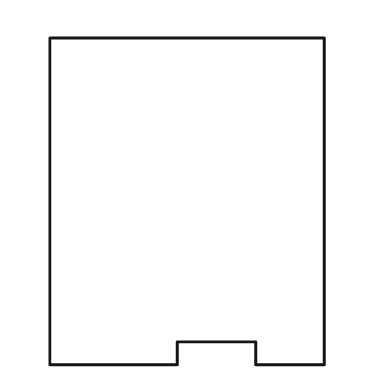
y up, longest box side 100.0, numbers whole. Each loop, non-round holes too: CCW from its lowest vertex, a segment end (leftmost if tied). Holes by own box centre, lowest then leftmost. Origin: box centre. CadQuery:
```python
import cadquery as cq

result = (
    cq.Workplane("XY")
    .moveTo(-42.0, -50.0)
    .lineTo(-3.0, -50.0)
    .lineTo(-3.0, -43.0)
    .lineTo(21.0, -43.0)
    .lineTo(21.0, -50.0)
    .lineTo(42.0, -50.0)
    .lineTo(42.0, 50.0)
    .lineTo(-42.0, 50.0)
    .close()
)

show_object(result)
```